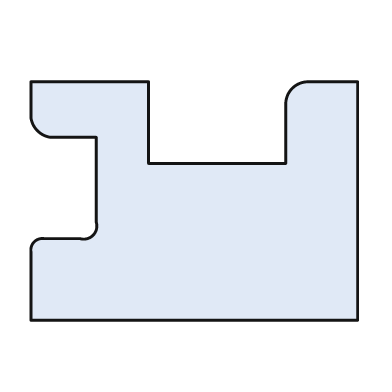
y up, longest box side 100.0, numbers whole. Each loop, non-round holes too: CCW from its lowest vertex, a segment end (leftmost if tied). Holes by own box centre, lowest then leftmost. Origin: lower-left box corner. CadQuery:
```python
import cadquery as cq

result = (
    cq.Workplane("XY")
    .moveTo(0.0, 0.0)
    .lineTo(100.0, 0.0)
    .lineTo(100.0, 73.0)
    .lineTo(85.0, 73.0)
    .threePointArc((80.0, 71.0), (78.0, 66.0))
    .lineTo(78.0, 48.0)
    .lineTo(36.0, 48.0)
    .lineTo(36.0, 73.0)
    .lineTo(0.0, 73.0)
    .lineTo(0.0, 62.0)
    .threePointArc((2.0, 58.0), (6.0, 56.0))
    .lineTo(20.0, 56.0)
    .lineTo(20.0, 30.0)
    .threePointArc((19.0, 26.0), (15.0, 25.0))
    .lineTo(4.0, 25.0)
    .threePointArc((1.0, 24.0), (0.0, 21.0))
    .close()
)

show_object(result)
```